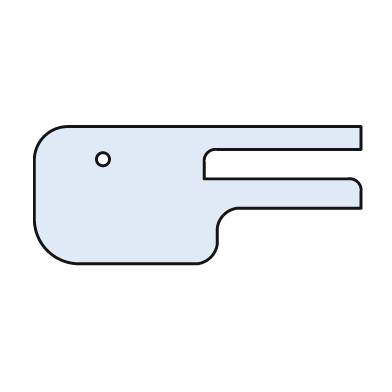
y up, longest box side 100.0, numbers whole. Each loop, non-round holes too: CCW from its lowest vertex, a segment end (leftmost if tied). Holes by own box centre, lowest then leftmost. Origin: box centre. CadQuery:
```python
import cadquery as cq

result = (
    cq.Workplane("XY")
    .moveTo(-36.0, -21.0)
    .lineTo(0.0, -21.0)
    .threePointArc((4.0, -19.0), (6.0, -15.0))
    .lineTo(6.0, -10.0)
    .threePointArc((8.0, -6.0), (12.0, -4.0))
    .lineTo(50.0, -4.0)
    .lineTo(50.0, 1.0)
    .threePointArc((49.0, 4.0), (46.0, 5.0))
    .lineTo(2.0, 5.0)
    .lineTo(2.0, 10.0)
    .threePointArc((3.0, 13.0), (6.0, 14.0))
    .lineTo(50.0, 14.0)
    .lineTo(50.0, 21.0)
    .lineTo(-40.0, 21.0)
    .threePointArc((-47.0, 18.0), (-50.0, 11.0))
    .lineTo(-50.0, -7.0)
    .threePointArc((-46.0, -17.0), (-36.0, -21.0))
    .close()
    .moveTo(-29.0, 11.0)
    .circle(2.0)
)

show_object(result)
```